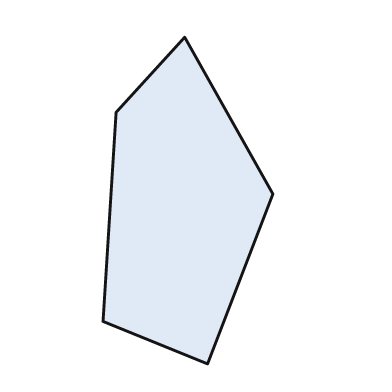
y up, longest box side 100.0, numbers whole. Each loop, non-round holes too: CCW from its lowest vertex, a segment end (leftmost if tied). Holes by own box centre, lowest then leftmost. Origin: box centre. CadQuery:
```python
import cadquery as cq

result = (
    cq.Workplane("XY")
    .moveTo(6.0, -50.0)
    .lineTo(26.0, 2.0)
    .lineTo(-1.0, 50.0)
    .lineTo(-22.0, 27.0)
    .lineTo(-26.0, -37.0)
    .close()
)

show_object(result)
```